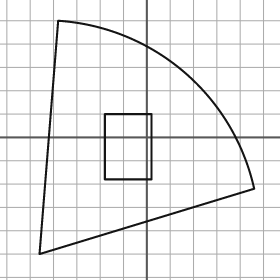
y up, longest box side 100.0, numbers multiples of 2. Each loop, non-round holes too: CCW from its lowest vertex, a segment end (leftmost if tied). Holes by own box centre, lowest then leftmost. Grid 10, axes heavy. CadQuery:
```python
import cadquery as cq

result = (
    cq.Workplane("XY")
    .moveTo(-46.0, -50.0)
    .lineTo(46.0, -22.0)
    .threePointArc((16.0, 28.0), (-38.0, 50.0))
    .close()
    .moveTo(-18.0, -18.0)
    .lineTo(2.0, -18.0)
    .lineTo(2.0, 10.0)
    .lineTo(-18.0, 10.0)
    .close()
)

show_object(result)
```